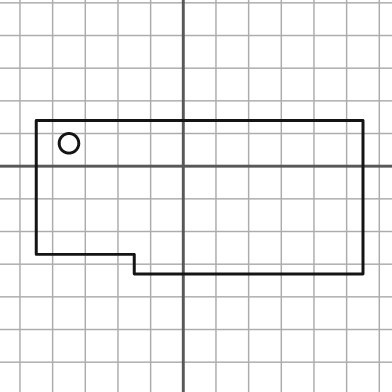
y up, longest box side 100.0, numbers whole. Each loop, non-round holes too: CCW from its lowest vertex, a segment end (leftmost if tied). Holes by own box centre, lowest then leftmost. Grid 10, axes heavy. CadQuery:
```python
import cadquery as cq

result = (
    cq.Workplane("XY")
    .moveTo(-15.0, -33.0)
    .lineTo(55.0, -33.0)
    .lineTo(55.0, 14.0)
    .lineTo(-45.0, 14.0)
    .lineTo(-45.0, -27.0)
    .lineTo(-15.0, -27.0)
    .close()
    .moveTo(-35.0, 7.0)
    .circle(3.0)
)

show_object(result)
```